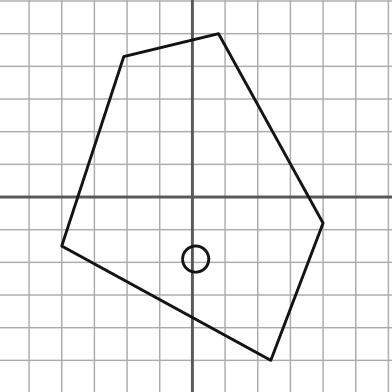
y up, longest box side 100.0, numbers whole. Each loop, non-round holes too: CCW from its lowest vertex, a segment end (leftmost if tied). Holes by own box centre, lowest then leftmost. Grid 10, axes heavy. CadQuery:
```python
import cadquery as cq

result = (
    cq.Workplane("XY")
    .moveTo(24.0, -50.0)
    .lineTo(40.0, -8.0)
    .lineTo(8.0, 50.0)
    .lineTo(-21.0, 43.0)
    .lineTo(-40.0, -15.0)
    .close()
    .moveTo(1.0, -19.0)
    .circle(4.0)
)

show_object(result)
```